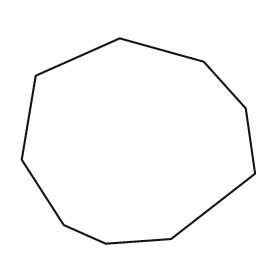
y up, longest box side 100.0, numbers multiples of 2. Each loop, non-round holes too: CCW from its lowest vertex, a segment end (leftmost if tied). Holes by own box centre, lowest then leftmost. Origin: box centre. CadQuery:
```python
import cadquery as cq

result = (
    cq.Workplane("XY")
    .moveTo(-14.0, -44.0)
    .lineTo(14.0, -42.0)
    .lineTo(50.0, -14.0)
    .lineTo(46.0, 14.0)
    .lineTo(28.0, 34.0)
    .lineTo(-8.0, 44.0)
    .lineTo(-44.0, 28.0)
    .lineTo(-50.0, -8.0)
    .lineTo(-32.0, -36.0)
    .close()
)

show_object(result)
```